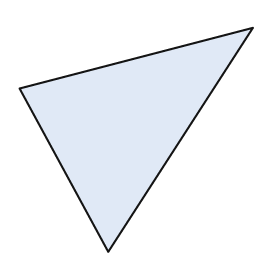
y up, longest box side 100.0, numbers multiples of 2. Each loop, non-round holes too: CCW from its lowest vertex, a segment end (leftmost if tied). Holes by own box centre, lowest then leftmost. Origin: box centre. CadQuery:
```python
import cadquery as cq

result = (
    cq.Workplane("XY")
    .moveTo(-12.0, -48.0)
    .lineTo(50.0, 48.0)
    .lineTo(-50.0, 22.0)
    .close()
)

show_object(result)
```